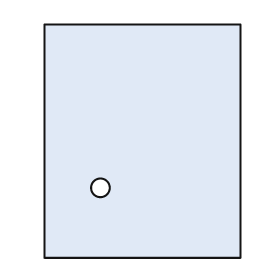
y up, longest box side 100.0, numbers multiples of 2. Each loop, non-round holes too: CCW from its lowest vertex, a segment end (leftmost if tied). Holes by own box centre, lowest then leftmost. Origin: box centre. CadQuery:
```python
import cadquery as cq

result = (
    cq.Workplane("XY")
    .moveTo(-42.0, -50.0)
    .lineTo(42.0, -50.0)
    .lineTo(42.0, 50.0)
    .lineTo(-42.0, 50.0)
    .close()
    .moveTo(-18.0, -20.0)
    .circle(4.0)
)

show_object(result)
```